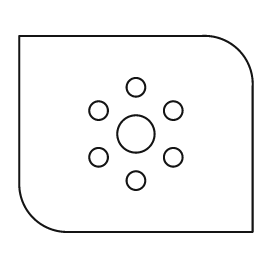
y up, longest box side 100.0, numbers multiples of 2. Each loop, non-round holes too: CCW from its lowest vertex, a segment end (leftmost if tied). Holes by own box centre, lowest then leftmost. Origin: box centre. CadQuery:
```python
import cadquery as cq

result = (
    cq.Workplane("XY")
    .moveTo(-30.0, -42.0)
    .lineTo(50.0, -42.0)
    .lineTo(50.0, 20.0)
    .threePointArc((44.0, 36.0), (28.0, 42.0))
    .lineTo(-50.0, 42.0)
    .lineTo(-50.0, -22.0)
    .threePointArc((-44.0, -36.0), (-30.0, -42.0))
    .close()
    .moveTo(0.0, -20.0)
    .circle(4.0)
    .moveTo(-16.0, -10.0)
    .circle(4.0)
    .moveTo(16.0, -10.0)
    .circle(4.0)
    .moveTo(0.0, 0.0)
    .circle(8.0)
    .moveTo(-16.0, 10.0)
    .circle(4.0)
    .moveTo(16.0, 10.0)
    .circle(4.0)
    .moveTo(0.0, 20.0)
    .circle(4.0)
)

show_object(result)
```